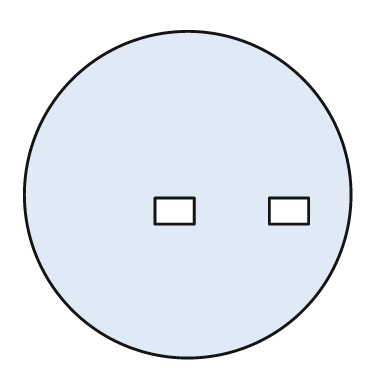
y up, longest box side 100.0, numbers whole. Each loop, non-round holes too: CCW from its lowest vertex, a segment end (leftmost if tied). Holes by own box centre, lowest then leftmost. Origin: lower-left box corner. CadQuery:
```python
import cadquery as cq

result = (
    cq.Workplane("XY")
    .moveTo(50.0, 50.0)
    .circle(50.0)
    .moveTo(40.0, 41.0)
    .lineTo(52.0, 41.0)
    .lineTo(52.0, 49.0)
    .lineTo(40.0, 49.0)
    .close()
    .moveTo(75.0, 41.0)
    .lineTo(87.0, 41.0)
    .lineTo(87.0, 49.0)
    .lineTo(75.0, 49.0)
    .close()
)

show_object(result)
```